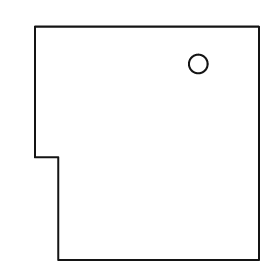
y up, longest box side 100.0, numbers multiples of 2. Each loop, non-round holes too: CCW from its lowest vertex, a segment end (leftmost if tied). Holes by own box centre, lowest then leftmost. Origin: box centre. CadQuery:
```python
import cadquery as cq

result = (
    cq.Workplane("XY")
    .moveTo(-38.0, -50.0)
    .lineTo(48.0, -50.0)
    .lineTo(48.0, 50.0)
    .lineTo(-48.0, 50.0)
    .lineTo(-48.0, -6.0)
    .lineTo(-38.0, -6.0)
    .close()
    .moveTo(22.0, 34.0)
    .circle(4.0)
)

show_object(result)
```